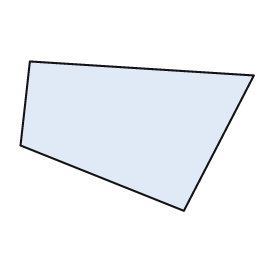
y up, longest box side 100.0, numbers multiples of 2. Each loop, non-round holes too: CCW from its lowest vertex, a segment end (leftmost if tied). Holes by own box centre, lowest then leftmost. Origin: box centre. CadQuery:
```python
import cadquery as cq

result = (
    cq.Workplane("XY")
    .moveTo(20.0, -32.0)
    .lineTo(50.0, 26.0)
    .lineTo(-46.0, 32.0)
    .lineTo(-50.0, -4.0)
    .close()
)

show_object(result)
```